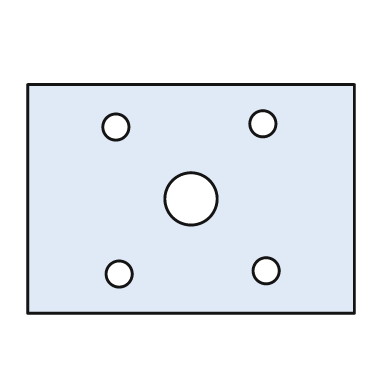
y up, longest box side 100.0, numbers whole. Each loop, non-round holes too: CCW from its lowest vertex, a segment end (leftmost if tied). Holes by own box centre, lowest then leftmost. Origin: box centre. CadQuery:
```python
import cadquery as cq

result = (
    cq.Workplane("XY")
    .moveTo(-50.0, -35.0)
    .lineTo(50.0, -35.0)
    .lineTo(50.0, 35.0)
    .lineTo(-50.0, 35.0)
    .close()
    .moveTo(-22.0, -23.0)
    .circle(4.0)
    .moveTo(23.0, -22.0)
    .circle(4.0)
    .moveTo(0.0, 0.0)
    .circle(8.0)
    .moveTo(-23.0, 22.0)
    .circle(4.0)
    .moveTo(22.0, 23.0)
    .circle(4.0)
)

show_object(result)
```